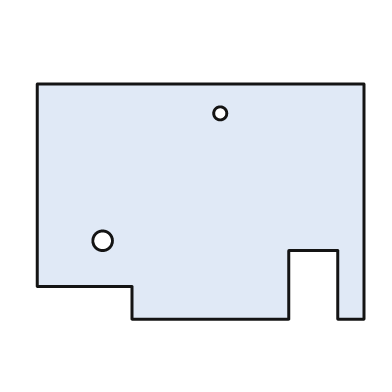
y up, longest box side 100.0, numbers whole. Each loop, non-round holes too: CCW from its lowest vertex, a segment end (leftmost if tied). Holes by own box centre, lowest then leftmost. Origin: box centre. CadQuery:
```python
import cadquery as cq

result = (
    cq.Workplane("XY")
    .moveTo(-21.0, -36.0)
    .lineTo(27.0, -36.0)
    .lineTo(27.0, -15.0)
    .lineTo(42.0, -15.0)
    .lineTo(42.0, -36.0)
    .lineTo(50.0, -36.0)
    .lineTo(50.0, 36.0)
    .lineTo(-50.0, 36.0)
    .lineTo(-50.0, -26.0)
    .lineTo(-21.0, -26.0)
    .close()
    .moveTo(-30.0, -12.0)
    .circle(3.0)
    .moveTo(6.0, 27.0)
    .circle(2.0)
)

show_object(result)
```